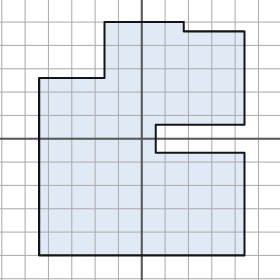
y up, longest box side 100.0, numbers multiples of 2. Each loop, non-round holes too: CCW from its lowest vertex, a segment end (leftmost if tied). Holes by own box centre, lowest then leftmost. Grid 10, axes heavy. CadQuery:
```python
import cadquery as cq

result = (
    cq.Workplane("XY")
    .moveTo(-44.0, -50.0)
    .lineTo(44.0, -50.0)
    .lineTo(44.0, -6.0)
    .lineTo(6.0, -6.0)
    .lineTo(6.0, 6.0)
    .lineTo(44.0, 6.0)
    .lineTo(44.0, 46.0)
    .lineTo(18.0, 46.0)
    .lineTo(18.0, 50.0)
    .lineTo(-16.0, 50.0)
    .lineTo(-16.0, 26.0)
    .lineTo(-44.0, 26.0)
    .close()
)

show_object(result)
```